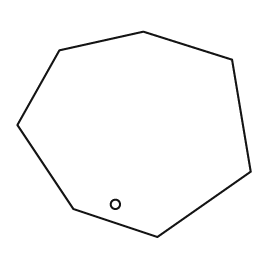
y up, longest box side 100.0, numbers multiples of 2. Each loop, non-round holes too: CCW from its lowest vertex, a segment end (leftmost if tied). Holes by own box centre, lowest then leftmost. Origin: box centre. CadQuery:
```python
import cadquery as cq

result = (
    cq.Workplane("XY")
    .moveTo(10.0, -44.0)
    .lineTo(50.0, -16.0)
    .lineTo(42.0, 32.0)
    .lineTo(4.0, 44.0)
    .lineTo(-32.0, 36.0)
    .lineTo(-50.0, 4.0)
    .lineTo(-26.0, -32.0)
    .close()
    .moveTo(-8.0, -30.0)
    .circle(2.0)
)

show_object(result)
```